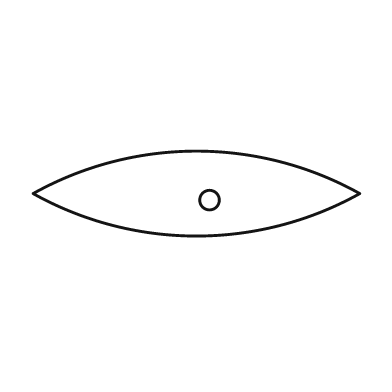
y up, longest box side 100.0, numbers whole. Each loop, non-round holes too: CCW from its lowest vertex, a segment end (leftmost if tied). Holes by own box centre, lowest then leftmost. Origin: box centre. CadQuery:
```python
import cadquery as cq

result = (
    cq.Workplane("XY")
    .moveTo(-50.0, 0.0)
    .threePointArc((0.0, -13.0), (50.0, 0.0))
    .threePointArc((0.0, 13.0), (-50.0, 0.0))
    .close()
    .moveTo(4.0, -2.0)
    .circle(3.0)
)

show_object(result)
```